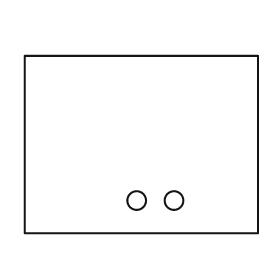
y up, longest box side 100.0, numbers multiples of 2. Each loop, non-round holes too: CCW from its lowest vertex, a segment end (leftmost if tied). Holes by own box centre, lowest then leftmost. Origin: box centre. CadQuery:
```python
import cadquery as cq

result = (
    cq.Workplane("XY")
    .moveTo(-50.0, -38.0)
    .lineTo(50.0, -38.0)
    .lineTo(50.0, 38.0)
    .lineTo(-50.0, 38.0)
    .close()
    .moveTo(-2.0, -24.0)
    .circle(4.0)
    .moveTo(14.0, -24.0)
    .circle(4.0)
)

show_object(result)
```